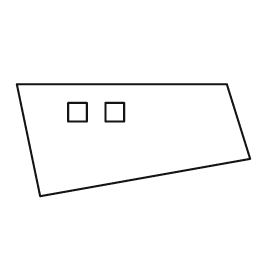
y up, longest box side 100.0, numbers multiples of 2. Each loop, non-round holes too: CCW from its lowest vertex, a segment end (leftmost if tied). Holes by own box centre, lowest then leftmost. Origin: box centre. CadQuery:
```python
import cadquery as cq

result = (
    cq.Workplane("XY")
    .moveTo(-40.0, -24.0)
    .lineTo(50.0, -8.0)
    .lineTo(40.0, 24.0)
    .lineTo(-50.0, 24.0)
    .close()
    .moveTo(-28.0, 8.0)
    .lineTo(-20.0, 8.0)
    .lineTo(-20.0, 16.0)
    .lineTo(-28.0, 16.0)
    .close()
    .moveTo(-12.0, 8.0)
    .lineTo(-4.0, 8.0)
    .lineTo(-4.0, 16.0)
    .lineTo(-12.0, 16.0)
    .close()
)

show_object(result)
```